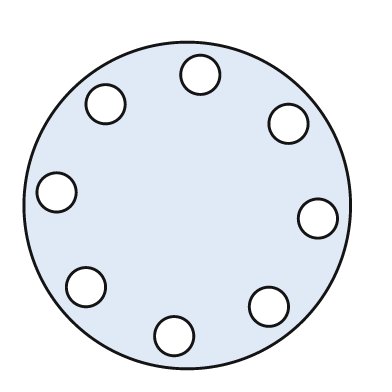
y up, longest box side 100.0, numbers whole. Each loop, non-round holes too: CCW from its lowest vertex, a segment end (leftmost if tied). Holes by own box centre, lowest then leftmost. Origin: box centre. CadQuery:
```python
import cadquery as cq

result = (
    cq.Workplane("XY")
    .moveTo(0.0, 0.0)
    .circle(50.0)
    .moveTo(-4.0, -40.0)
    .circle(6.0)
    .moveTo(25.0, -31.0)
    .circle(6.0)
    .moveTo(-31.0, -25.0)
    .circle(6.0)
    .moveTo(40.0, -4.0)
    .circle(6.0)
    .moveTo(-40.0, 4.0)
    .circle(6.0)
    .moveTo(31.0, 25.0)
    .circle(6.0)
    .moveTo(-25.0, 31.0)
    .circle(6.0)
    .moveTo(4.0, 40.0)
    .circle(6.0)
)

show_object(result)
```